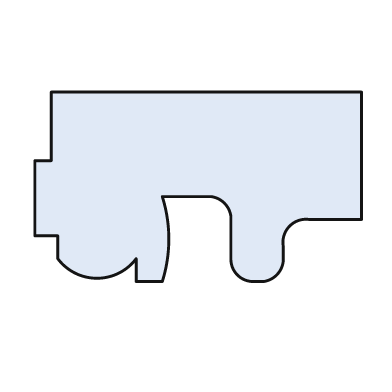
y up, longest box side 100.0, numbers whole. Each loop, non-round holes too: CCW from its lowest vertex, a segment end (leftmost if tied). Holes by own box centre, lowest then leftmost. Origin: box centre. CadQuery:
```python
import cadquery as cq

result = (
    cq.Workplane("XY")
    .moveTo(-19.0, -29.0)
    .lineTo(-11.0, -29.0)
    .threePointArc((-9.0, -16.0), (-11.0, -3.0))
    .lineTo(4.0, -3.0)
    .threePointArc((8.0, -5.0), (10.0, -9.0))
    .lineTo(10.0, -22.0)
    .threePointArc((12.0, -27.0), (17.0, -29.0))
    .lineTo(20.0, -29.0)
    .threePointArc((24.0, -27.0), (26.0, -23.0))
    .lineTo(26.0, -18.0)
    .threePointArc((28.0, -12.0), (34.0, -10.0))
    .lineTo(50.0, -10.0)
    .lineTo(50.0, 29.0)
    .lineTo(-45.0, 29.0)
    .lineTo(-45.0, 8.0)
    .lineTo(-50.0, 8.0)
    .lineTo(-50.0, -15.0)
    .lineTo(-43.0, -15.0)
    .lineTo(-43.0, -22.0)
    .threePointArc((-31.0, -28.0), (-19.0, -22.0))
    .close()
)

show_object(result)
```